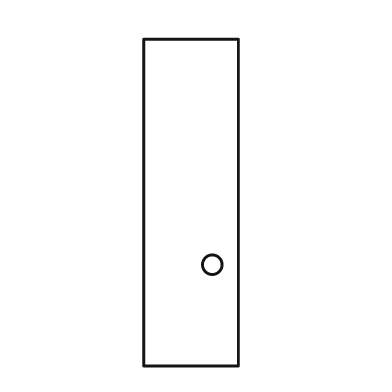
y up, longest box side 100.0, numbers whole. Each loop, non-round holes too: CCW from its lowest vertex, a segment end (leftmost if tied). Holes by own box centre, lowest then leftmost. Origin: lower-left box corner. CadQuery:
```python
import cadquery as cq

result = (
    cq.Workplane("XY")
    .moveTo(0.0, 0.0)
    .lineTo(29.0, 0.0)
    .lineTo(29.0, 100.0)
    .lineTo(0.0, 100.0)
    .close()
    .moveTo(21.0, 31.0)
    .circle(3.0)
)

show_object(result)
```